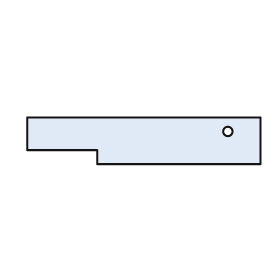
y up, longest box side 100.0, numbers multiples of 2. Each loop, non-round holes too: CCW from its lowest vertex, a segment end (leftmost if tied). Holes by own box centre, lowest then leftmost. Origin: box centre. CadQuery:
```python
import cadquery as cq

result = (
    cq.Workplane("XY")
    .moveTo(-20.0, -10.0)
    .lineTo(50.0, -10.0)
    .lineTo(50.0, 10.0)
    .lineTo(-50.0, 10.0)
    .lineTo(-50.0, -4.0)
    .lineTo(-20.0, -4.0)
    .close()
    .moveTo(36.0, 4.0)
    .circle(2.0)
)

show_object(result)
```